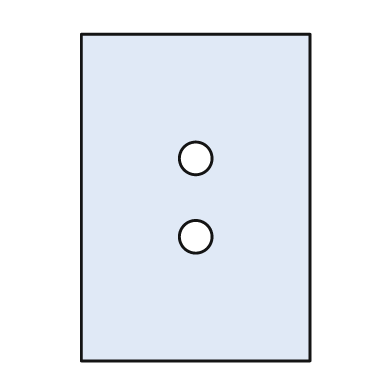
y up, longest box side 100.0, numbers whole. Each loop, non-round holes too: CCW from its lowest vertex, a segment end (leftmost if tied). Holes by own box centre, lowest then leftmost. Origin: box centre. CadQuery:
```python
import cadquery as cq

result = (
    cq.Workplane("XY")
    .moveTo(-35.0, -50.0)
    .lineTo(35.0, -50.0)
    .lineTo(35.0, 50.0)
    .lineTo(-35.0, 50.0)
    .close()
    .moveTo(0.0, -12.0)
    .circle(5.0)
    .moveTo(0.0, 12.0)
    .circle(5.0)
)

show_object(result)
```